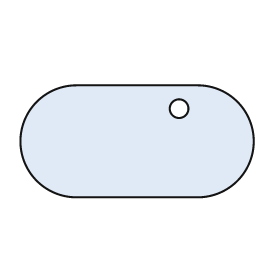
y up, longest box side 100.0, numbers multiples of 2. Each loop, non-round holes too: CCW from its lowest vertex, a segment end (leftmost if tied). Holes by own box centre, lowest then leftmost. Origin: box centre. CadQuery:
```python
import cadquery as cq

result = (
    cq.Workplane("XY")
    .moveTo(-26.0, -24.0)
    .lineTo(26.0, -24.0)
    .threePointArc((50.0, 0.0), (26.0, 24.0))
    .lineTo(-26.0, 24.0)
    .threePointArc((-50.0, 0.0), (-26.0, -24.0))
    .close()
    .moveTo(18.0, 14.0)
    .circle(4.0)
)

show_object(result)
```